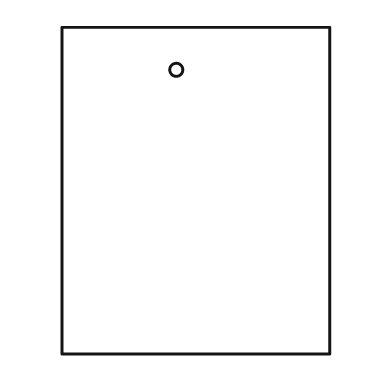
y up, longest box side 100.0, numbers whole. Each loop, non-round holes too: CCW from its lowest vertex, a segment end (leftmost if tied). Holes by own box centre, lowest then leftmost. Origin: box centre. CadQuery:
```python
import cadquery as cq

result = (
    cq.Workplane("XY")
    .moveTo(-41.0, -50.0)
    .lineTo(41.0, -50.0)
    .lineTo(41.0, 50.0)
    .lineTo(-41.0, 50.0)
    .close()
    .moveTo(-6.0, 37.0)
    .circle(2.0)
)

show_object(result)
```